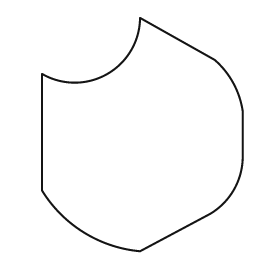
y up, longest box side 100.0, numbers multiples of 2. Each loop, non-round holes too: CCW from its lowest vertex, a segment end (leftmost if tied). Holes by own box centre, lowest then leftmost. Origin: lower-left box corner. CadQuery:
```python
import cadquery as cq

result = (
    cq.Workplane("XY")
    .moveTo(42.0, 0.0)
    .lineTo(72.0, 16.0)
    .threePointArc((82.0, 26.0), (86.0, 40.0))
    .lineTo(86.0, 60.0)
    .threePointArc((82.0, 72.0), (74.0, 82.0))
    .lineTo(42.0, 100.0)
    .threePointArc((28.0, 76.0), (0.0, 76.0))
    .lineTo(0.0, 26.0)
    .threePointArc((18.0, 8.0), (42.0, 0.0))
    .close()
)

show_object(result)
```